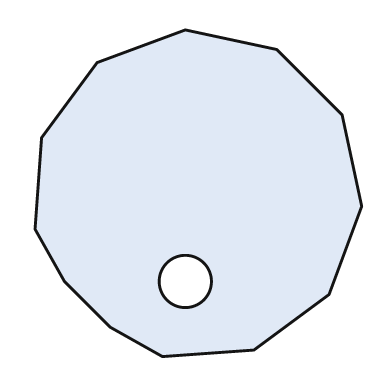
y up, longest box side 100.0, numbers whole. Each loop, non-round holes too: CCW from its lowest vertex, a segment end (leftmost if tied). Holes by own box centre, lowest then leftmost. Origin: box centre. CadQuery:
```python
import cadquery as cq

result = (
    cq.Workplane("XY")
    .moveTo(-11.0, -50.0)
    .lineTo(17.0, -48.0)
    .lineTo(40.0, -31.0)
    .lineTo(50.0, -4.0)
    .lineTo(44.0, 24.0)
    .lineTo(24.0, 44.0)
    .lineTo(-4.0, 50.0)
    .lineTo(-31.0, 40.0)
    .lineTo(-48.0, 17.0)
    .lineTo(-50.0, -11.0)
    .lineTo(-41.0, -27.0)
    .lineTo(-27.0, -41.0)
    .close()
    .moveTo(-4.0, -27.0)
    .circle(8.0)
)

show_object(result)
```